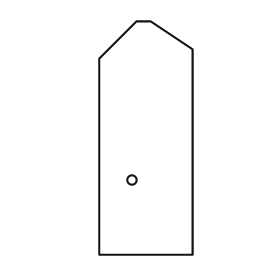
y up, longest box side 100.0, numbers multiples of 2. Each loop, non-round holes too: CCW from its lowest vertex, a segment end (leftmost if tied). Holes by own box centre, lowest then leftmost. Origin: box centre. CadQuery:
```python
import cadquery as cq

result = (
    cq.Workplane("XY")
    .moveTo(-20.0, -50.0)
    .lineTo(20.0, -50.0)
    .lineTo(20.0, 38.0)
    .lineTo(2.0, 50.0)
    .lineTo(-4.0, 50.0)
    .lineTo(-20.0, 34.0)
    .close()
    .moveTo(-6.0, -18.0)
    .circle(2.0)
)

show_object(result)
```